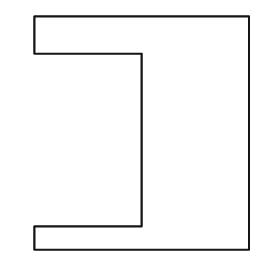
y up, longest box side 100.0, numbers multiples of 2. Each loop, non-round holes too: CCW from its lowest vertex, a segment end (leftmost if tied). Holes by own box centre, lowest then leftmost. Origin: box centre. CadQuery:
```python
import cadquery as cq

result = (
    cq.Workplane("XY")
    .moveTo(-46.0, -50.0)
    .lineTo(46.0, -50.0)
    .lineTo(46.0, 50.0)
    .lineTo(-46.0, 50.0)
    .lineTo(-46.0, 34.0)
    .lineTo(0.0, 34.0)
    .lineTo(0.0, -40.0)
    .lineTo(-46.0, -40.0)
    .close()
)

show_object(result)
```